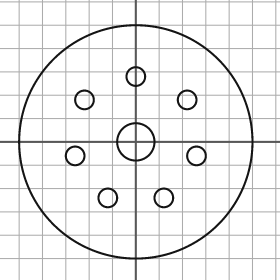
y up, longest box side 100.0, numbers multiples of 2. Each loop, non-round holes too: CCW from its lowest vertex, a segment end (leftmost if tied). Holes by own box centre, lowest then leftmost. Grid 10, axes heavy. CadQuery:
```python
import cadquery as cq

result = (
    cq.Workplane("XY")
    .moveTo(0.0, 0.0)
    .circle(50.0)
    .moveTo(-12.0, -24.0)
    .circle(4.0)
    .moveTo(12.0, -24.0)
    .circle(4.0)
    .moveTo(-26.0, -6.0)
    .circle(4.0)
    .moveTo(26.0, -6.0)
    .circle(4.0)
    .moveTo(0.0, 0.0)
    .circle(8.0)
    .moveTo(-22.0, 18.0)
    .circle(4.0)
    .moveTo(22.0, 18.0)
    .circle(4.0)
    .moveTo(0.0, 28.0)
    .circle(4.0)
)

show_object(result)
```